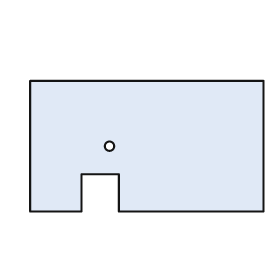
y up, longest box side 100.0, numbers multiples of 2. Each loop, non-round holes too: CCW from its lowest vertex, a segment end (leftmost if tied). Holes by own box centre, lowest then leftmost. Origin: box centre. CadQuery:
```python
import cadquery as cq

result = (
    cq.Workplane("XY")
    .moveTo(-50.0, -28.0)
    .lineTo(-28.0, -28.0)
    .lineTo(-28.0, -12.0)
    .lineTo(-12.0, -12.0)
    .lineTo(-12.0, -28.0)
    .lineTo(50.0, -28.0)
    .lineTo(50.0, 28.0)
    .lineTo(-50.0, 28.0)
    .close()
    .moveTo(-16.0, 0.0)
    .circle(2.0)
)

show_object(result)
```